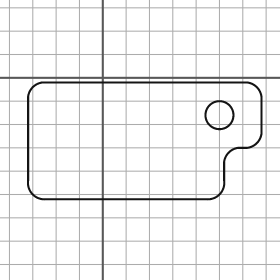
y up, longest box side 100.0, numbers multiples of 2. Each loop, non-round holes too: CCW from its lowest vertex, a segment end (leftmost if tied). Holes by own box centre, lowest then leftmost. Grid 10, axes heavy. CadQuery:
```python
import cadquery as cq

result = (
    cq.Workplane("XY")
    .moveTo(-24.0, -52.0)
    .lineTo(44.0, -52.0)
    .threePointArc((50.0, -50.0), (52.0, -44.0))
    .lineTo(52.0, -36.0)
    .threePointArc((54.0, -32.0), (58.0, -30.0))
    .lineTo(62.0, -30.0)
    .threePointArc((66.0, -28.0), (68.0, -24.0))
    .lineTo(68.0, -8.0)
    .threePointArc((66.0, -4.0), (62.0, -2.0))
    .lineTo(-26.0, -2.0)
    .threePointArc((-30.0, -4.0), (-32.0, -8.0))
    .lineTo(-32.0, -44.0)
    .threePointArc((-30.0, -50.0), (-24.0, -52.0))
    .close()
    .moveTo(50.0, -16.0)
    .circle(6.0)
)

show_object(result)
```